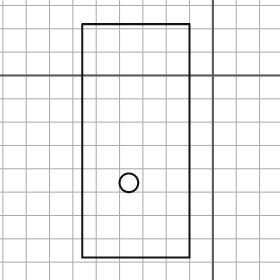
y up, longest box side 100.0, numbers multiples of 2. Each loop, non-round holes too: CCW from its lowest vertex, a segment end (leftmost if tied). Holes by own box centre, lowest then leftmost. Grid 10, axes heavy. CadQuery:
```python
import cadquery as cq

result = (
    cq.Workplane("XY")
    .moveTo(-56.0, -78.0)
    .lineTo(-10.0, -78.0)
    .lineTo(-10.0, 22.0)
    .lineTo(-56.0, 22.0)
    .close()
    .moveTo(-36.0, -46.0)
    .circle(4.0)
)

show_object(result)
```